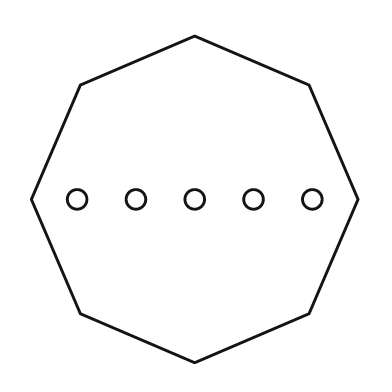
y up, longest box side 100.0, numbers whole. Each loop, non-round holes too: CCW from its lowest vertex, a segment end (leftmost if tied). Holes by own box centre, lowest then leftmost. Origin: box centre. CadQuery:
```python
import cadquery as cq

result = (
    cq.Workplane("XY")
    .moveTo(0.0, -50.0)
    .lineTo(35.0, -35.0)
    .lineTo(50.0, 0.0)
    .lineTo(35.0, 35.0)
    .lineTo(0.0, 50.0)
    .lineTo(-35.0, 35.0)
    .lineTo(-50.0, 0.0)
    .lineTo(-35.0, -35.0)
    .close()
    .moveTo(-36.0, 0.0)
    .circle(3.0)
    .moveTo(-18.0, 0.0)
    .circle(3.0)
    .moveTo(0.0, 0.0)
    .circle(3.0)
    .moveTo(18.0, 0.0)
    .circle(3.0)
    .moveTo(36.0, 0.0)
    .circle(3.0)
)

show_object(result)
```